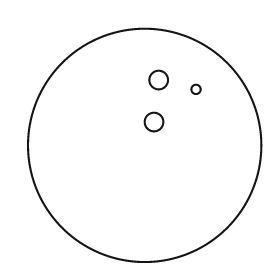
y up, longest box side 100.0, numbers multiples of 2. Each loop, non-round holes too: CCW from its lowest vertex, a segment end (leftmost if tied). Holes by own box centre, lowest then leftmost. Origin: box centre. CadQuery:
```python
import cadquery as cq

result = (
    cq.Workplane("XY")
    .moveTo(0.0, 0.0)
    .circle(50.0)
    .moveTo(4.0, 10.0)
    .circle(4.0)
    .moveTo(22.0, 24.0)
    .circle(2.0)
    .moveTo(6.0, 28.0)
    .circle(4.0)
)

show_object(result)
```